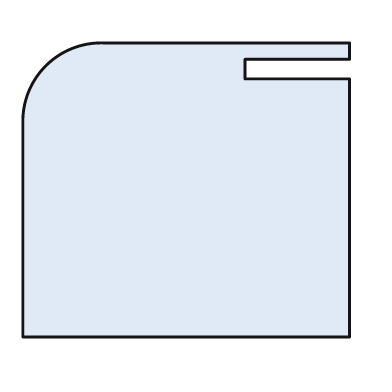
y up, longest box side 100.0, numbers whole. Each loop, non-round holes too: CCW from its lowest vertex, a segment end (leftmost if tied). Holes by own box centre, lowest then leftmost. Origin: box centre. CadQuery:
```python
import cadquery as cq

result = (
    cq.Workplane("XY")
    .moveTo(-50.0, -45.0)
    .lineTo(50.0, -45.0)
    .lineTo(50.0, 34.0)
    .lineTo(18.0, 34.0)
    .lineTo(18.0, 40.0)
    .lineTo(50.0, 40.0)
    .lineTo(50.0, 45.0)
    .lineTo(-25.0, 45.0)
    .threePointArc((-43.0, 38.0), (-50.0, 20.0))
    .close()
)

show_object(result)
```